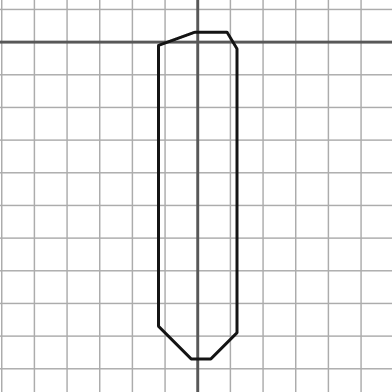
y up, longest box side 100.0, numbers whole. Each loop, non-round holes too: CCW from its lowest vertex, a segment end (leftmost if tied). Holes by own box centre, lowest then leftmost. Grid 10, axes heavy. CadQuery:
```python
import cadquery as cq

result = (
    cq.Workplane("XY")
    .moveTo(-2.0, -97.0)
    .lineTo(4.0, -97.0)
    .lineTo(12.0, -89.0)
    .lineTo(12.0, -2.0)
    .lineTo(9.0, 3.0)
    .lineTo(-1.0, 3.0)
    .lineTo(-12.0, -1.0)
    .lineTo(-12.0, -87.0)
    .close()
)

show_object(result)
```